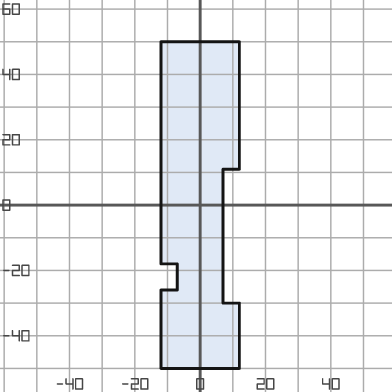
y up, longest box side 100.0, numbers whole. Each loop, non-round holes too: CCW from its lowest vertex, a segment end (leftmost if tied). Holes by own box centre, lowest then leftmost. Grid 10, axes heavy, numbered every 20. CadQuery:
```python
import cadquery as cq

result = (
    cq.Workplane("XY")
    .moveTo(-12.0, -50.0)
    .lineTo(12.0, -50.0)
    .lineTo(12.0, -30.0)
    .lineTo(7.0, -30.0)
    .lineTo(7.0, 11.0)
    .lineTo(12.0, 11.0)
    .lineTo(12.0, 50.0)
    .lineTo(-12.0, 50.0)
    .lineTo(-12.0, -18.0)
    .lineTo(-7.0, -18.0)
    .lineTo(-7.0, -26.0)
    .lineTo(-12.0, -26.0)
    .close()
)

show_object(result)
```